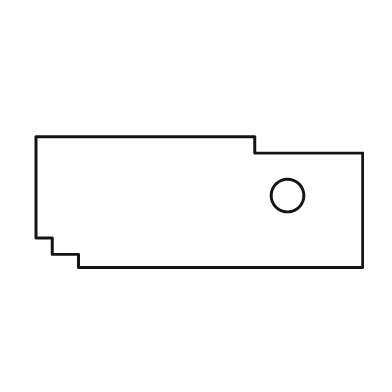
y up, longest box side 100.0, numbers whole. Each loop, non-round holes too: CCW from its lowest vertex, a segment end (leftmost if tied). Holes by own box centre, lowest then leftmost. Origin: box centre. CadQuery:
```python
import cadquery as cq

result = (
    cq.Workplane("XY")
    .moveTo(-37.0, -20.0)
    .lineTo(50.0, -20.0)
    .lineTo(50.0, 15.0)
    .lineTo(17.0, 15.0)
    .lineTo(17.0, 20.0)
    .lineTo(-50.0, 20.0)
    .lineTo(-50.0, -11.0)
    .lineTo(-45.0, -11.0)
    .lineTo(-45.0, -16.0)
    .lineTo(-37.0, -16.0)
    .close()
    .moveTo(27.0, 2.0)
    .circle(5.0)
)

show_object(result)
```